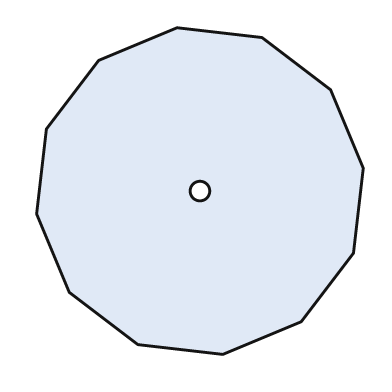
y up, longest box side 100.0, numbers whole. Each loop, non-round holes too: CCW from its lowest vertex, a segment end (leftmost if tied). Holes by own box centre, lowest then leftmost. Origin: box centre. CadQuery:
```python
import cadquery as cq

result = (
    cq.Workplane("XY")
    .moveTo(7.0, -50.0)
    .lineTo(31.0, -40.0)
    .lineTo(47.0, -19.0)
    .lineTo(50.0, 7.0)
    .lineTo(40.0, 31.0)
    .lineTo(19.0, 47.0)
    .lineTo(-7.0, 50.0)
    .lineTo(-31.0, 40.0)
    .lineTo(-47.0, 19.0)
    .lineTo(-50.0, -7.0)
    .lineTo(-40.0, -31.0)
    .lineTo(-19.0, -47.0)
    .close()
    .moveTo(0.0, 0.0)
    .circle(3.0)
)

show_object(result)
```